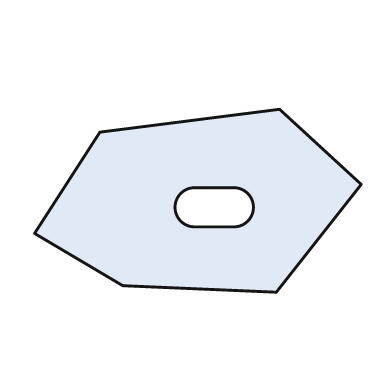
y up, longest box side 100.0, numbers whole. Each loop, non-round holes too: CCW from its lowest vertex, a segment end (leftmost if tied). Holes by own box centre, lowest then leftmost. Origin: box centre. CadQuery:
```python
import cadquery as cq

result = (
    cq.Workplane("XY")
    .moveTo(24.0, -28.0)
    .lineTo(50.0, 5.0)
    .lineTo(25.0, 28.0)
    .lineTo(-30.0, 21.0)
    .lineTo(-50.0, -10.0)
    .lineTo(-23.0, -26.0)
    .close()
    .moveTo(-1.0, -8.0)
    .lineTo(11.0, -8.0)
    .threePointArc((17.0, -2.0), (11.0, 4.0))
    .lineTo(-1.0, 4.0)
    .threePointArc((-7.0, -2.0), (-1.0, -8.0))
    .close()
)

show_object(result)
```